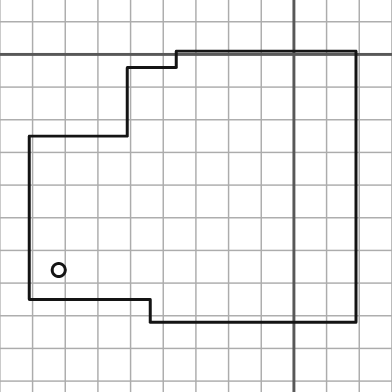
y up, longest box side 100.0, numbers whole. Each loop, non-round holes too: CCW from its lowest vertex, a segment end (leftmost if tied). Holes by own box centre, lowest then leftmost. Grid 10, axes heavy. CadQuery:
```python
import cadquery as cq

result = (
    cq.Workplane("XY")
    .moveTo(-44.0, -82.0)
    .lineTo(19.0, -82.0)
    .lineTo(19.0, 1.0)
    .lineTo(-36.0, 1.0)
    .lineTo(-36.0, -4.0)
    .lineTo(-51.0, -4.0)
    .lineTo(-51.0, -25.0)
    .lineTo(-81.0, -25.0)
    .lineTo(-81.0, -75.0)
    .lineTo(-44.0, -75.0)
    .close()
    .moveTo(-72.0, -66.0)
    .circle(2.0)
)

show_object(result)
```